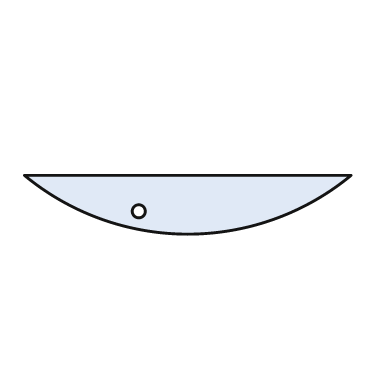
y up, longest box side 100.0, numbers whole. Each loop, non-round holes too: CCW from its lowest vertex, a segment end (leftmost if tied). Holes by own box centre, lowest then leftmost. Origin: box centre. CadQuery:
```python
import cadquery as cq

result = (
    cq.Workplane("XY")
    .moveTo(-50.0, 9.0)
    .threePointArc((0.0, -9.0), (50.0, 9.0))
    .close()
    .moveTo(-15.0, -2.0)
    .circle(2.0)
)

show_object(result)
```